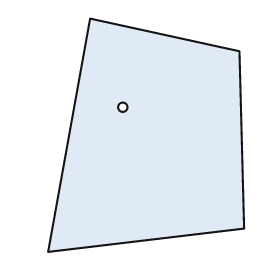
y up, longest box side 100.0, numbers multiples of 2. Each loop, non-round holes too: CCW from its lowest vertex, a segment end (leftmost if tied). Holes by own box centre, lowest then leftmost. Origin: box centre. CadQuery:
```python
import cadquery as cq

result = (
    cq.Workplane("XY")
    .moveTo(-42.0, -50.0)
    .lineTo(42.0, -40.0)
    .lineTo(40.0, 36.0)
    .lineTo(-24.0, 50.0)
    .close()
    .moveTo(-10.0, 12.0)
    .circle(2.0)
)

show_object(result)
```